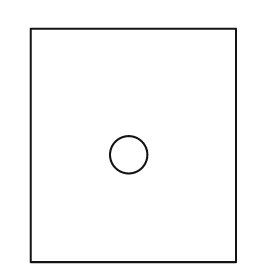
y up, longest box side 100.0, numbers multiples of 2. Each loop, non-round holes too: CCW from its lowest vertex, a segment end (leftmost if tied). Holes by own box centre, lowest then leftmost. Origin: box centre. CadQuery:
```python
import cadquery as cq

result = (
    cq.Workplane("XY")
    .moveTo(-44.0, -50.0)
    .lineTo(44.0, -50.0)
    .lineTo(44.0, 50.0)
    .lineTo(-44.0, 50.0)
    .close()
    .moveTo(-2.0, -4.0)
    .circle(8.0)
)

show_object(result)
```